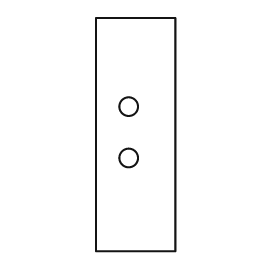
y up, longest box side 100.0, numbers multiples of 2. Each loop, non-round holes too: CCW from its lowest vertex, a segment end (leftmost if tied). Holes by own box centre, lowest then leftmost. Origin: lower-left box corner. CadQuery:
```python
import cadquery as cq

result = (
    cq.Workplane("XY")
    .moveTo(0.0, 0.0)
    .lineTo(34.0, 0.0)
    .lineTo(34.0, 100.0)
    .lineTo(0.0, 100.0)
    .close()
    .moveTo(14.0, 40.0)
    .circle(4.0)
    .moveTo(14.0, 62.0)
    .circle(4.0)
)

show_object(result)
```